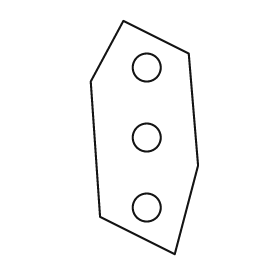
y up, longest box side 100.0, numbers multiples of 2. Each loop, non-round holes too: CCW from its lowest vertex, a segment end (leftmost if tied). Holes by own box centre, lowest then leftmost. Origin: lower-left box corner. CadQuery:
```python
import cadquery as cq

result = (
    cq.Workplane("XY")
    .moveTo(36.0, 0.0)
    .lineTo(46.0, 38.0)
    .lineTo(42.0, 86.0)
    .lineTo(14.0, 100.0)
    .lineTo(0.0, 74.0)
    .lineTo(4.0, 16.0)
    .close()
    .moveTo(24.0, 20.0)
    .circle(6.0)
    .moveTo(24.0, 50.0)
    .circle(6.0)
    .moveTo(24.0, 80.0)
    .circle(6.0)
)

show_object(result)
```